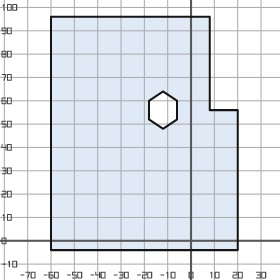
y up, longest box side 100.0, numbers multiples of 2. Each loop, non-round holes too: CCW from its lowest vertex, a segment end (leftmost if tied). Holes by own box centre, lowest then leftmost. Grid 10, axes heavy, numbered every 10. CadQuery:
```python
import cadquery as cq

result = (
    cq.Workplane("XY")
    .moveTo(-60.0, -4.0)
    .lineTo(20.0, -4.0)
    .lineTo(20.0, 56.0)
    .lineTo(8.0, 56.0)
    .lineTo(8.0, 96.0)
    .lineTo(-60.0, 96.0)
    .close()
    .moveTo(-12.0, 48.0)
    .lineTo(-6.0, 52.0)
    .lineTo(-6.0, 60.0)
    .lineTo(-12.0, 64.0)
    .lineTo(-18.0, 60.0)
    .lineTo(-18.0, 52.0)
    .close()
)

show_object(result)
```